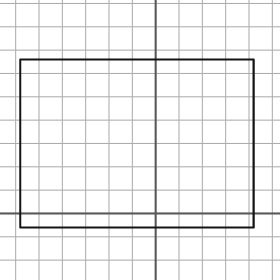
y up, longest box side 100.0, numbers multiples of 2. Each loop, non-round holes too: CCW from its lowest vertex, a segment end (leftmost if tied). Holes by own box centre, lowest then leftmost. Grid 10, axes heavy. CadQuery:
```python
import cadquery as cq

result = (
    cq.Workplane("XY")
    .moveTo(-58.0, -6.0)
    .lineTo(42.0, -6.0)
    .lineTo(42.0, 66.0)
    .lineTo(-58.0, 66.0)
    .close()
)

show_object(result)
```